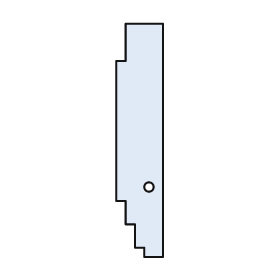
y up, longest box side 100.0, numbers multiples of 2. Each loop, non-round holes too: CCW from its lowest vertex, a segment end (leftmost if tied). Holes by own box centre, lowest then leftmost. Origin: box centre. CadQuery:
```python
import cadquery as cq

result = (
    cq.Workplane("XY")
    .moveTo(2.0, -50.0)
    .lineTo(10.0, -50.0)
    .lineTo(10.0, 50.0)
    .lineTo(-6.0, 50.0)
    .lineTo(-6.0, 34.0)
    .lineTo(-10.0, 34.0)
    .lineTo(-10.0, -26.0)
    .lineTo(-6.0, -26.0)
    .lineTo(-6.0, -36.0)
    .lineTo(-2.0, -36.0)
    .lineTo(-2.0, -46.0)
    .lineTo(2.0, -46.0)
    .close()
    .moveTo(4.0, -20.0)
    .circle(2.0)
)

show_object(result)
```